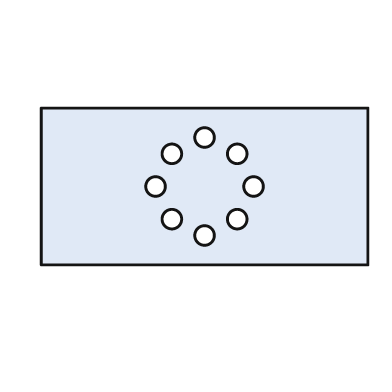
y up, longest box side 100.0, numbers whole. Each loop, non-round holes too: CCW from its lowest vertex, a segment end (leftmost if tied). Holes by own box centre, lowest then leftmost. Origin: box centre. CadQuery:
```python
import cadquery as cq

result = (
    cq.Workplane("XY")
    .moveTo(-50.0, -24.0)
    .lineTo(50.0, -24.0)
    .lineTo(50.0, 24.0)
    .lineTo(-50.0, 24.0)
    .close()
    .moveTo(0.0, -15.0)
    .circle(3.0)
    .moveTo(-10.0, -10.0)
    .circle(3.0)
    .moveTo(10.0, -10.0)
    .circle(3.0)
    .moveTo(-15.0, 0.0)
    .circle(3.0)
    .moveTo(15.0, 0.0)
    .circle(3.0)
    .moveTo(-10.0, 10.0)
    .circle(3.0)
    .moveTo(10.0, 10.0)
    .circle(3.0)
    .moveTo(0.0, 15.0)
    .circle(3.0)
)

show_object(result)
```